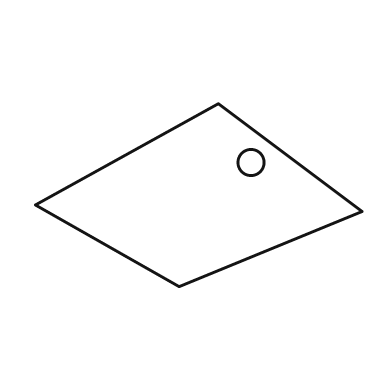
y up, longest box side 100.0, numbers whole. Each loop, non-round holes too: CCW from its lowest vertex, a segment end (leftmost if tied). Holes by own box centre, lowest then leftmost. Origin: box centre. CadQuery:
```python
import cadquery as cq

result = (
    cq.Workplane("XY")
    .moveTo(-6.0, -28.0)
    .lineTo(50.0, -5.0)
    .lineTo(6.0, 28.0)
    .lineTo(-50.0, -3.0)
    .close()
    .moveTo(16.0, 10.0)
    .circle(4.0)
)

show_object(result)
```